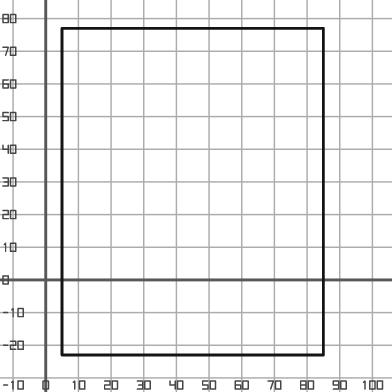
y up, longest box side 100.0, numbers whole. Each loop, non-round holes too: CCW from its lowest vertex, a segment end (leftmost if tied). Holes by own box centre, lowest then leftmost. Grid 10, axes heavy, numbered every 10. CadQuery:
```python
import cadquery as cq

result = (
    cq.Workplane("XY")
    .moveTo(5.0, -23.0)
    .lineTo(85.0, -23.0)
    .lineTo(85.0, 77.0)
    .lineTo(5.0, 77.0)
    .close()
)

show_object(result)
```